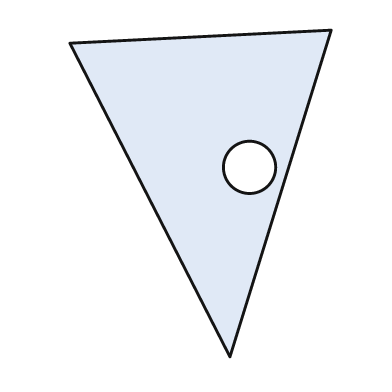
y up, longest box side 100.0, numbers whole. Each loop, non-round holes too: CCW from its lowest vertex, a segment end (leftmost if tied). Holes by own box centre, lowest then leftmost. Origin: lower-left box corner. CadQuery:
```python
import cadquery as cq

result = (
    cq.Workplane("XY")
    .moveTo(49.0, 0.0)
    .lineTo(80.0, 100.0)
    .lineTo(0.0, 96.0)
    .close()
    .moveTo(55.0, 58.0)
    .circle(8.0)
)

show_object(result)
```